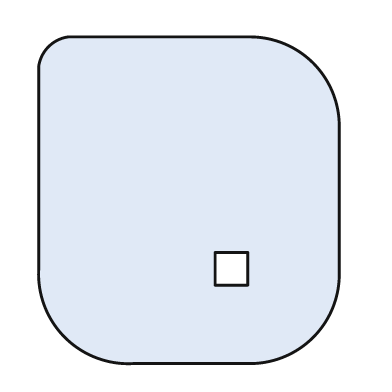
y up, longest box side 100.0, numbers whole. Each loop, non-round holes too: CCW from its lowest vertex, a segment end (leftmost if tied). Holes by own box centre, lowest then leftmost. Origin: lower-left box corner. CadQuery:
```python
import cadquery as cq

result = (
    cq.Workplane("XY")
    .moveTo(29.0, 0.0)
    .lineTo(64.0, 0.0)
    .threePointArc((84.0, 8.0), (92.0, 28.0))
    .lineTo(92.0, 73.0)
    .threePointArc((84.0, 92.0), (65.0, 100.0))
    .lineTo(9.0, 100.0)
    .threePointArc((3.0, 97.0), (0.0, 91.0))
    .lineTo(0.0, 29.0)
    .threePointArc((8.0, 8.0), (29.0, 0.0))
    .close()
    .moveTo(54.0, 24.0)
    .lineTo(64.0, 24.0)
    .lineTo(64.0, 34.0)
    .lineTo(54.0, 34.0)
    .close()
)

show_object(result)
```